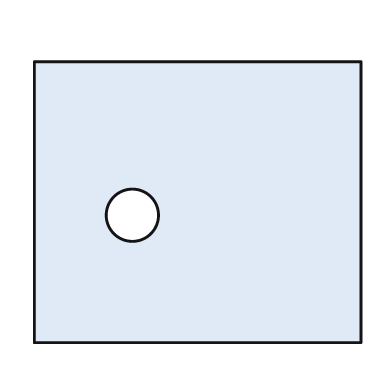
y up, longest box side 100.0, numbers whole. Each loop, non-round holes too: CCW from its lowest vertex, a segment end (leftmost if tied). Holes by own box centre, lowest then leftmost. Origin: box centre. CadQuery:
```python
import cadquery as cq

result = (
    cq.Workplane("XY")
    .moveTo(-50.0, -43.0)
    .lineTo(50.0, -43.0)
    .lineTo(50.0, 43.0)
    .lineTo(-50.0, 43.0)
    .close()
    .moveTo(-20.0, -4.0)
    .circle(8.0)
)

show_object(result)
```